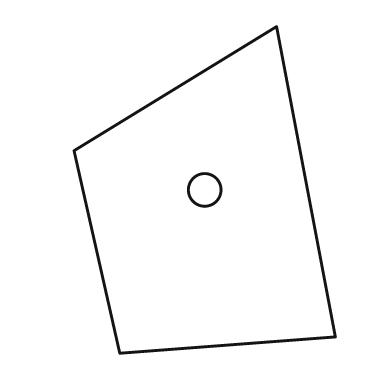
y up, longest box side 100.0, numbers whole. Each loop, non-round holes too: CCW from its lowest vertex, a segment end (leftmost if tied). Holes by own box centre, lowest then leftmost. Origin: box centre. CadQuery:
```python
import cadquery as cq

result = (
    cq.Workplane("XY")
    .moveTo(-26.0, -50.0)
    .lineTo(40.0, -45.0)
    .lineTo(22.0, 50.0)
    .lineTo(-40.0, 12.0)
    .close()
    .moveTo(0.0, 0.0)
    .circle(5.0)
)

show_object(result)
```